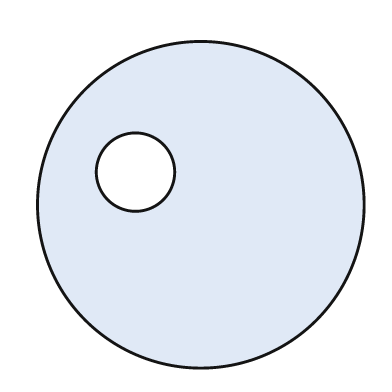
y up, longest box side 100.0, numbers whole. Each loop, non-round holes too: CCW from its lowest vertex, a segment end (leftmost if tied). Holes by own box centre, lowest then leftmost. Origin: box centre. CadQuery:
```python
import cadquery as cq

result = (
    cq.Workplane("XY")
    .moveTo(0.0, 0.0)
    .circle(50.0)
    .moveTo(-20.0, 10.0)
    .circle(12.0)
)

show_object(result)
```